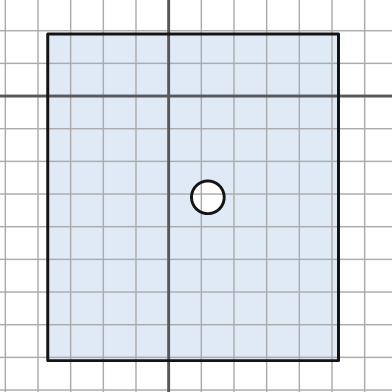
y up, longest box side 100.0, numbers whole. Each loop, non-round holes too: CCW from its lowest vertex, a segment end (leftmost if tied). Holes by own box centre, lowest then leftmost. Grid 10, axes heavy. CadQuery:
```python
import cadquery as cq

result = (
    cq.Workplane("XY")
    .moveTo(-37.0, -81.0)
    .lineTo(52.0, -81.0)
    .lineTo(52.0, 19.0)
    .lineTo(-37.0, 19.0)
    .close()
    .moveTo(12.0, -31.0)
    .circle(5.0)
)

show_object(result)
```